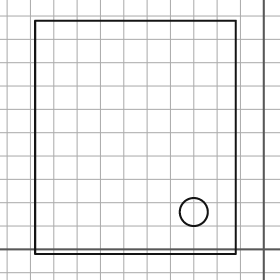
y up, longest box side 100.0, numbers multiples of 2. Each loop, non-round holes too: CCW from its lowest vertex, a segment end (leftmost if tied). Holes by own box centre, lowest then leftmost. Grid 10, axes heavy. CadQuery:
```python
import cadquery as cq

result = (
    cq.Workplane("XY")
    .moveTo(-98.0, -2.0)
    .lineTo(-12.0, -2.0)
    .lineTo(-12.0, 98.0)
    .lineTo(-98.0, 98.0)
    .close()
    .moveTo(-30.0, 16.0)
    .circle(6.0)
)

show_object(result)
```